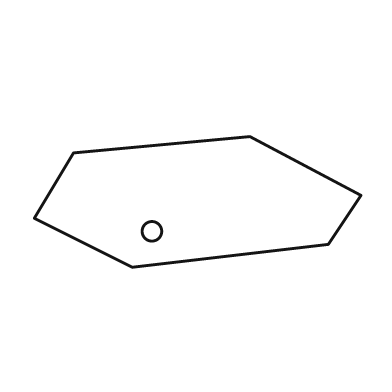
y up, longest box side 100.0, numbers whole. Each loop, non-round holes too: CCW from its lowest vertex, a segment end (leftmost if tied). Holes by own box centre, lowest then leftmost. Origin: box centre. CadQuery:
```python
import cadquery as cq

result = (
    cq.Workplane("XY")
    .moveTo(-20.0, -20.0)
    .lineTo(40.0, -13.0)
    .lineTo(50.0, 2.0)
    .lineTo(16.0, 20.0)
    .lineTo(-38.0, 15.0)
    .lineTo(-50.0, -5.0)
    .close()
    .moveTo(-14.0, -9.0)
    .circle(3.0)
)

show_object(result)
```